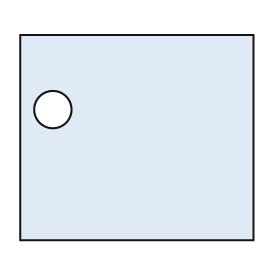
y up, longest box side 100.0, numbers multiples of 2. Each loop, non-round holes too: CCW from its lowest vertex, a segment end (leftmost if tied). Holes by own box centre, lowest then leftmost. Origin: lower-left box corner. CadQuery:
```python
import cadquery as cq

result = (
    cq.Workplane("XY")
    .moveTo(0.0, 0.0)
    .lineTo(100.0, 0.0)
    .lineTo(100.0, 88.0)
    .lineTo(0.0, 88.0)
    .close()
    .moveTo(14.0, 56.0)
    .circle(8.0)
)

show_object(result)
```